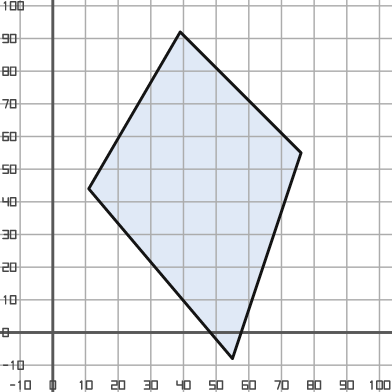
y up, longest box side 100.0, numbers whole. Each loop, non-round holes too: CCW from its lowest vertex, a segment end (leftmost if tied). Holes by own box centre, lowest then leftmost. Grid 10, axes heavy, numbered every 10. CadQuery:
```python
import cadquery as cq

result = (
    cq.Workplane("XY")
    .moveTo(55.0, -8.0)
    .lineTo(76.0, 55.0)
    .lineTo(39.0, 92.0)
    .lineTo(11.0, 44.0)
    .close()
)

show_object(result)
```